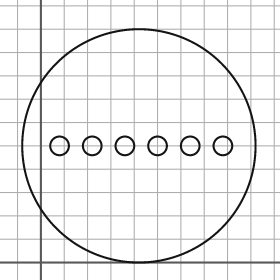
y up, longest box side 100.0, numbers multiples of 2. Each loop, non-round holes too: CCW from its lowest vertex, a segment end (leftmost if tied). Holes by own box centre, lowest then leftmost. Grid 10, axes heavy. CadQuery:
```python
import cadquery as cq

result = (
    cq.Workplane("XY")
    .moveTo(42.0, 50.0)
    .circle(50.0)
    .moveTo(8.0, 50.0)
    .circle(4.0)
    .moveTo(22.0, 50.0)
    .circle(4.0)
    .moveTo(36.0, 50.0)
    .circle(4.0)
    .moveTo(50.0, 50.0)
    .circle(4.0)
    .moveTo(64.0, 50.0)
    .circle(4.0)
    .moveTo(78.0, 50.0)
    .circle(4.0)
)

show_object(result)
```